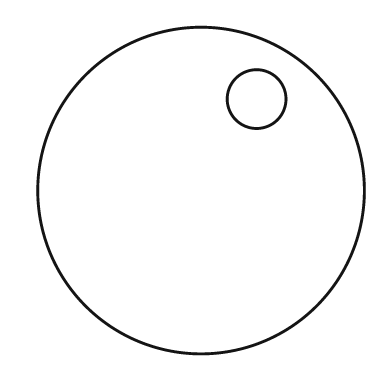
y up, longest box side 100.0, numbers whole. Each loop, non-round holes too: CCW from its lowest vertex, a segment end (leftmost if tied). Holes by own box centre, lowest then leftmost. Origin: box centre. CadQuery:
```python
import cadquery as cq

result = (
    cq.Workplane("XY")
    .moveTo(0.0, 0.0)
    .circle(50.0)
    .moveTo(17.0, 28.0)
    .circle(9.0)
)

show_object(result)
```